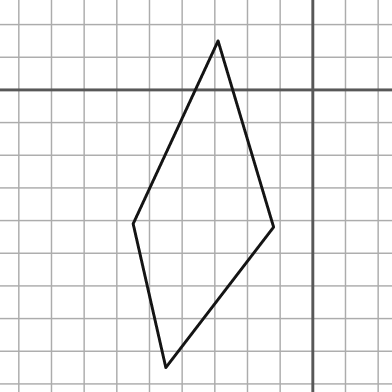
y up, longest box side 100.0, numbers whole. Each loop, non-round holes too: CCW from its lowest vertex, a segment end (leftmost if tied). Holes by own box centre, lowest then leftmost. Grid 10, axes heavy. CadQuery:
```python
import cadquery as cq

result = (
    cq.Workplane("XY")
    .moveTo(-45.0, -85.0)
    .lineTo(-12.0, -42.0)
    .lineTo(-29.0, 15.0)
    .lineTo(-55.0, -41.0)
    .close()
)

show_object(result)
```